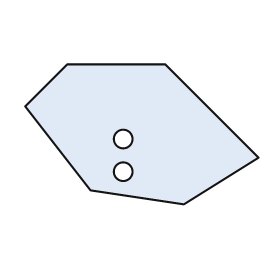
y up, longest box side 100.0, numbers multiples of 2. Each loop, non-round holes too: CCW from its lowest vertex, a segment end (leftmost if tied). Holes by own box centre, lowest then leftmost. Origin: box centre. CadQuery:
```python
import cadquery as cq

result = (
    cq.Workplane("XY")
    .moveTo(18.0, -30.0)
    .lineTo(50.0, -10.0)
    .lineTo(10.0, 30.0)
    .lineTo(-32.0, 30.0)
    .lineTo(-50.0, 12.0)
    .lineTo(-22.0, -24.0)
    .close()
    .moveTo(-8.0, -16.0)
    .circle(4.0)
    .moveTo(-8.0, -2.0)
    .circle(4.0)
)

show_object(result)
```